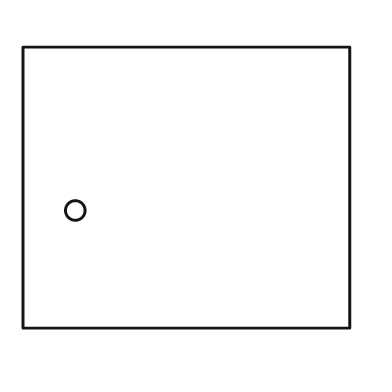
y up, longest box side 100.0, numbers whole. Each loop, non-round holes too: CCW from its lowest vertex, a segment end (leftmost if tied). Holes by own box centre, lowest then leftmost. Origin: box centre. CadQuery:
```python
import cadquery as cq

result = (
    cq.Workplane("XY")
    .moveTo(-50.0, -43.0)
    .lineTo(50.0, -43.0)
    .lineTo(50.0, 43.0)
    .lineTo(-50.0, 43.0)
    .close()
    .moveTo(-34.0, -7.0)
    .circle(3.0)
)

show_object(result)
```